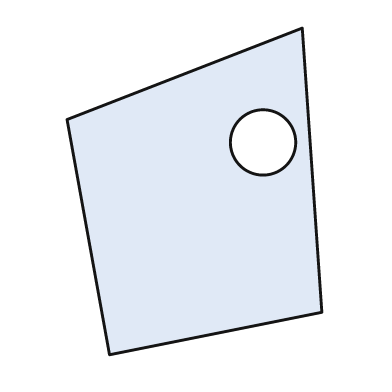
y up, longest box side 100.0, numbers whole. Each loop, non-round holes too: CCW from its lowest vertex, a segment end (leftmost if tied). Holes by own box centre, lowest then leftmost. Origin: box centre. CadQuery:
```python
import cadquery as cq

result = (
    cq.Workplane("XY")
    .moveTo(-26.0, -50.0)
    .lineTo(39.0, -37.0)
    .lineTo(33.0, 50.0)
    .lineTo(-39.0, 22.0)
    .close()
    .moveTo(21.0, 15.0)
    .circle(10.0)
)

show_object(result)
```